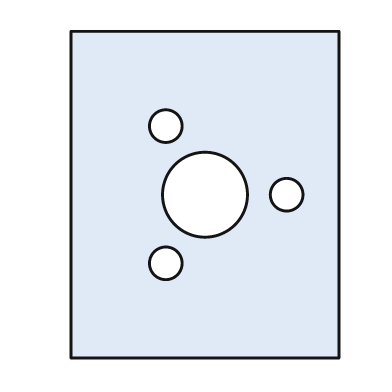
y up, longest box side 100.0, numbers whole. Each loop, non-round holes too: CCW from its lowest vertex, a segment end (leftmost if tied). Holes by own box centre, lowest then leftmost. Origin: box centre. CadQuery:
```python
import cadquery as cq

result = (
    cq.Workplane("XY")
    .moveTo(-41.0, -50.0)
    .lineTo(41.0, -50.0)
    .lineTo(41.0, 50.0)
    .lineTo(-41.0, 50.0)
    .close()
    .moveTo(-12.0, -21.0)
    .circle(5.0)
    .moveTo(0.0, 0.0)
    .circle(13.0)
    .moveTo(25.0, 0.0)
    .circle(5.0)
    .moveTo(-12.0, 21.0)
    .circle(5.0)
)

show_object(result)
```